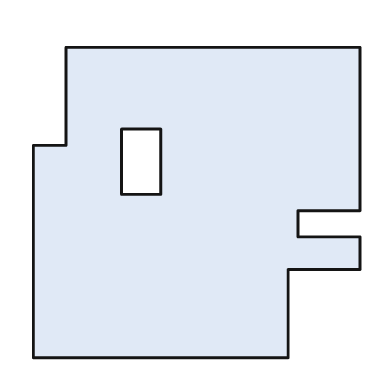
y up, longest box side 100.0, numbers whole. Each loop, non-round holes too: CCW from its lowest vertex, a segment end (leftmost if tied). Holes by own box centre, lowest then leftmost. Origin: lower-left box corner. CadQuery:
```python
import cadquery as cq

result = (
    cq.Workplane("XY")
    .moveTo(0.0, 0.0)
    .lineTo(78.0, 0.0)
    .lineTo(78.0, 27.0)
    .lineTo(100.0, 27.0)
    .lineTo(100.0, 37.0)
    .lineTo(81.0, 37.0)
    .lineTo(81.0, 45.0)
    .lineTo(100.0, 45.0)
    .lineTo(100.0, 95.0)
    .lineTo(10.0, 95.0)
    .lineTo(10.0, 65.0)
    .lineTo(0.0, 65.0)
    .close()
    .moveTo(27.0, 50.0)
    .lineTo(39.0, 50.0)
    .lineTo(39.0, 70.0)
    .lineTo(27.0, 70.0)
    .close()
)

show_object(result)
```